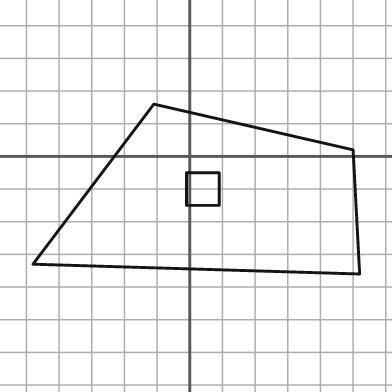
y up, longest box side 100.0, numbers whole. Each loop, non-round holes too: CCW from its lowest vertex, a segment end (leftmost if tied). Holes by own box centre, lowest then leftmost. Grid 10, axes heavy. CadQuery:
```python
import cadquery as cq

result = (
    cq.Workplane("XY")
    .moveTo(52.0, -36.0)
    .lineTo(50.0, 2.0)
    .lineTo(-11.0, 16.0)
    .lineTo(-48.0, -33.0)
    .close()
    .moveTo(-1.0, -15.0)
    .lineTo(9.0, -15.0)
    .lineTo(9.0, -5.0)
    .lineTo(-1.0, -5.0)
    .close()
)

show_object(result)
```